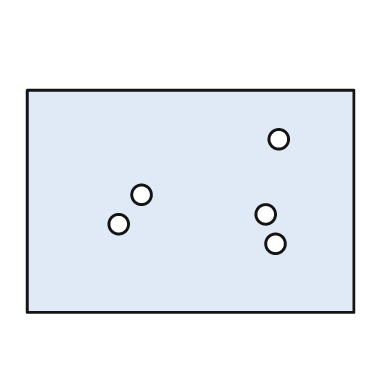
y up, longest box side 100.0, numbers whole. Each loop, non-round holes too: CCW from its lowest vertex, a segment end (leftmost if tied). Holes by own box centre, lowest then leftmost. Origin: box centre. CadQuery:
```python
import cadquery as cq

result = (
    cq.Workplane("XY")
    .moveTo(-50.0, -34.0)
    .lineTo(50.0, -34.0)
    .lineTo(50.0, 34.0)
    .lineTo(-50.0, 34.0)
    .close()
    .moveTo(26.0, -13.0)
    .circle(3.0)
    .moveTo(-22.0, -7.0)
    .circle(3.0)
    .moveTo(23.0, -4.0)
    .circle(3.0)
    .moveTo(-15.0, 2.0)
    .circle(3.0)
    .moveTo(27.0, 19.0)
    .circle(3.0)
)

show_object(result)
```